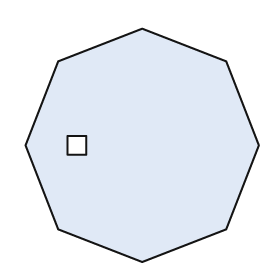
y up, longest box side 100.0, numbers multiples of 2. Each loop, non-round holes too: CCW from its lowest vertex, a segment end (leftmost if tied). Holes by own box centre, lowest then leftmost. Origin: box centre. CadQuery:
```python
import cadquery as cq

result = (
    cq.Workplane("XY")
    .moveTo(0.0, -50.0)
    .lineTo(36.0, -36.0)
    .lineTo(50.0, 0.0)
    .lineTo(36.0, 36.0)
    .lineTo(0.0, 50.0)
    .lineTo(-36.0, 36.0)
    .lineTo(-50.0, 0.0)
    .lineTo(-36.0, -36.0)
    .close()
    .moveTo(-32.0, -4.0)
    .lineTo(-24.0, -4.0)
    .lineTo(-24.0, 4.0)
    .lineTo(-32.0, 4.0)
    .close()
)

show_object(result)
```